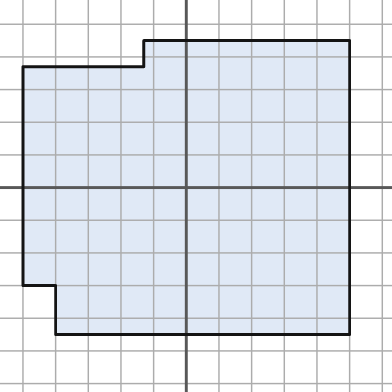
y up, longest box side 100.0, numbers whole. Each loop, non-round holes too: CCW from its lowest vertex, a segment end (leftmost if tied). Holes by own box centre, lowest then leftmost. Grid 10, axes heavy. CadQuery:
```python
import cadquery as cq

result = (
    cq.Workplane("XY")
    .moveTo(-40.0, -45.0)
    .lineTo(50.0, -45.0)
    .lineTo(50.0, 45.0)
    .lineTo(-13.0, 45.0)
    .lineTo(-13.0, 37.0)
    .lineTo(-50.0, 37.0)
    .lineTo(-50.0, -30.0)
    .lineTo(-40.0, -30.0)
    .close()
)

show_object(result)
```